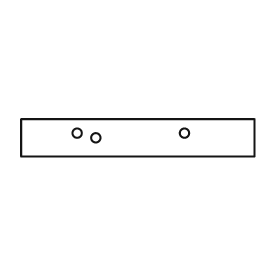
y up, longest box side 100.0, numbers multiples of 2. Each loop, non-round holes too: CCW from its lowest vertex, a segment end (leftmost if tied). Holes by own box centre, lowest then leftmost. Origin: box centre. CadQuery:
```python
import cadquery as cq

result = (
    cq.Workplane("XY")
    .moveTo(-50.0, -8.0)
    .lineTo(50.0, -8.0)
    .lineTo(50.0, 8.0)
    .lineTo(-50.0, 8.0)
    .close()
    .moveTo(-18.0, 0.0)
    .circle(2.0)
    .moveTo(-26.0, 2.0)
    .circle(2.0)
    .moveTo(20.0, 2.0)
    .circle(2.0)
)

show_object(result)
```